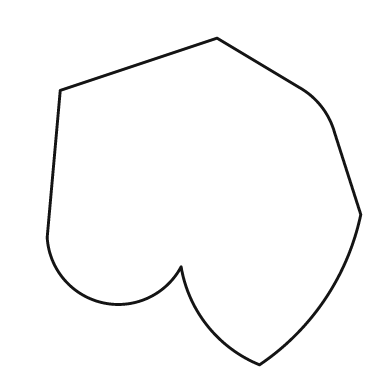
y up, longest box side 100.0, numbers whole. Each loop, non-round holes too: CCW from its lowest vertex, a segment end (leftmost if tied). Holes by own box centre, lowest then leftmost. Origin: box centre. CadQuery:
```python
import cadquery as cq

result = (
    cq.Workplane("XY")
    .moveTo(17.0, -50.0)
    .threePointArc((37.0, -30.0), (48.0, -4.0))
    .lineTo(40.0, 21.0)
    .threePointArc((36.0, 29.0), (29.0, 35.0))
    .lineTo(4.0, 50.0)
    .lineTo(-44.0, 34.0)
    .lineTo(-48.0, -11.0)
    .threePointArc((-31.0, -31.0), (-7.0, -20.0))
    .threePointArc((1.0, -38.0), (17.0, -50.0))
    .close()
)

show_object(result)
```